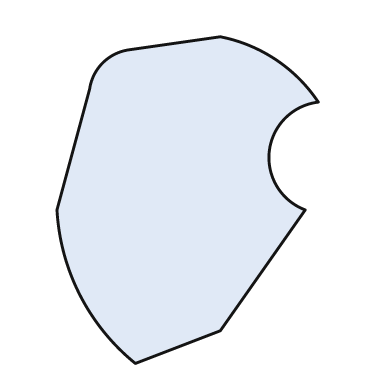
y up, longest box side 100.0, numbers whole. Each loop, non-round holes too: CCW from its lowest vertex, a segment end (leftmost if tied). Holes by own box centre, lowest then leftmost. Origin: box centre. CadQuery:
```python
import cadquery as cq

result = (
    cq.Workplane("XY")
    .moveTo(-16.0, -50.0)
    .lineTo(10.0, -40.0)
    .lineTo(36.0, -3.0)
    .threePointArc((25.0, 15.0), (40.0, 30.0))
    .threePointArc((27.0, 43.0), (10.0, 50.0))
    .lineTo(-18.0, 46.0)
    .threePointArc((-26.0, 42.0), (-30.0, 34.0))
    .lineTo(-40.0, -3.0)
    .threePointArc((-33.0, -29.0), (-16.0, -50.0))
    .close()
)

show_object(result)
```